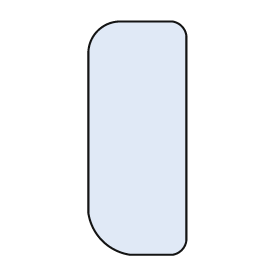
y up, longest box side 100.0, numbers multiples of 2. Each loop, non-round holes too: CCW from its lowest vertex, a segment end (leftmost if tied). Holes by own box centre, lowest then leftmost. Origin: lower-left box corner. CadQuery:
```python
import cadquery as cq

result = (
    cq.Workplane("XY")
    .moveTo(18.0, 0.0)
    .lineTo(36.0, 0.0)
    .threePointArc((40.0, 2.0), (42.0, 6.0))
    .lineTo(42.0, 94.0)
    .threePointArc((40.0, 98.0), (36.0, 100.0))
    .lineTo(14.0, 100.0)
    .threePointArc((4.0, 96.0), (0.0, 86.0))
    .lineTo(0.0, 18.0)
    .threePointArc((6.0, 6.0), (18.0, 0.0))
    .close()
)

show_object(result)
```